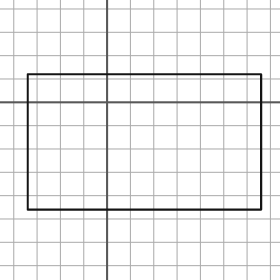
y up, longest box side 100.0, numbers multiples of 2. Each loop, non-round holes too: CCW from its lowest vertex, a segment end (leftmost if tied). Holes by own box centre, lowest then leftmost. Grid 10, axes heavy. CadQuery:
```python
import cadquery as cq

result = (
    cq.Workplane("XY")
    .moveTo(-34.0, -46.0)
    .lineTo(66.0, -46.0)
    .lineTo(66.0, 12.0)
    .lineTo(-34.0, 12.0)
    .close()
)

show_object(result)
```